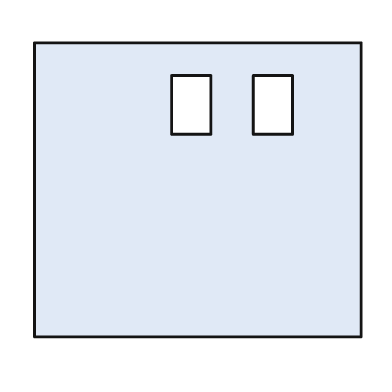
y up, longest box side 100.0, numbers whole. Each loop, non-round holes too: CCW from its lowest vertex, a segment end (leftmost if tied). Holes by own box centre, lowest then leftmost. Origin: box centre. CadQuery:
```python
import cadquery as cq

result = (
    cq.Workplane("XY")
    .moveTo(-50.0, -45.0)
    .lineTo(50.0, -45.0)
    .lineTo(50.0, 45.0)
    .lineTo(-50.0, 45.0)
    .close()
    .moveTo(-8.0, 17.0)
    .lineTo(4.0, 17.0)
    .lineTo(4.0, 35.0)
    .lineTo(-8.0, 35.0)
    .close()
    .moveTo(17.0, 17.0)
    .lineTo(29.0, 17.0)
    .lineTo(29.0, 35.0)
    .lineTo(17.0, 35.0)
    .close()
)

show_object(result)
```